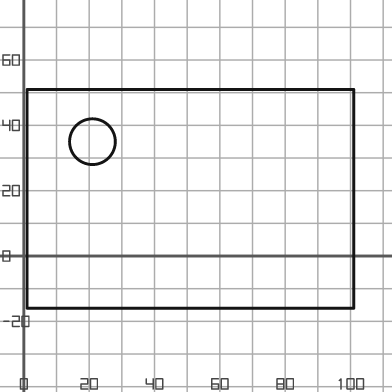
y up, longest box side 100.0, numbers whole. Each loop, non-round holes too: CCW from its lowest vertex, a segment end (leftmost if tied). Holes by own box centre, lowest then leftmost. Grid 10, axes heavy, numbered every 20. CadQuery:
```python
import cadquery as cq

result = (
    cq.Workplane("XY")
    .moveTo(1.0, -16.0)
    .lineTo(101.0, -16.0)
    .lineTo(101.0, 51.0)
    .lineTo(1.0, 51.0)
    .close()
    .moveTo(21.0, 35.0)
    .circle(7.0)
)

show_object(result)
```